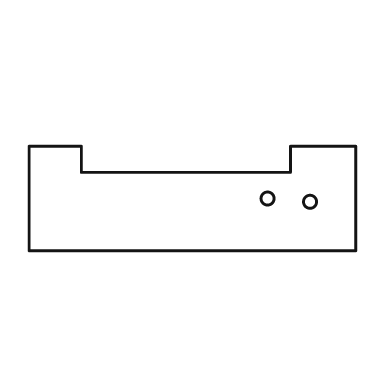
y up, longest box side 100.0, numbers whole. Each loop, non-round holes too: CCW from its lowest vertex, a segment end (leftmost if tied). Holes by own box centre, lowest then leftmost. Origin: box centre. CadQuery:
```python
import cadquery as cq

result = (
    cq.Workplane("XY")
    .moveTo(-50.0, -16.0)
    .lineTo(50.0, -16.0)
    .lineTo(50.0, 16.0)
    .lineTo(30.0, 16.0)
    .lineTo(30.0, 8.0)
    .lineTo(-34.0, 8.0)
    .lineTo(-34.0, 16.0)
    .lineTo(-50.0, 16.0)
    .close()
    .moveTo(36.0, -1.0)
    .circle(2.0)
    .moveTo(23.0, 0.0)
    .circle(2.0)
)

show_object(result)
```